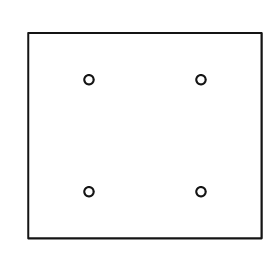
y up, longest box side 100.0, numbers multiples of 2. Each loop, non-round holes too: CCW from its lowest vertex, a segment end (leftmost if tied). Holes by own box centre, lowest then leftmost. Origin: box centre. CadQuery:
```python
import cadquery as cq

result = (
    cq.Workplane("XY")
    .moveTo(-50.0, -44.0)
    .lineTo(50.0, -44.0)
    .lineTo(50.0, 44.0)
    .lineTo(-50.0, 44.0)
    .close()
    .moveTo(-24.0, -24.0)
    .circle(2.0)
    .moveTo(24.0, -24.0)
    .circle(2.0)
    .moveTo(-24.0, 24.0)
    .circle(2.0)
    .moveTo(24.0, 24.0)
    .circle(2.0)
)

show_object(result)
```